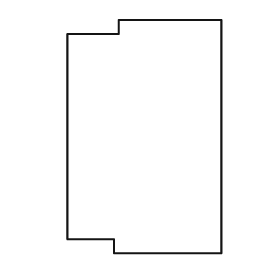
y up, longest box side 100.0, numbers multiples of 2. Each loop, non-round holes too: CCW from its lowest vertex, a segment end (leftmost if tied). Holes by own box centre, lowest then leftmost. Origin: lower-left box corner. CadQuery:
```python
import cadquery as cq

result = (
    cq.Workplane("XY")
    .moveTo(20.0, 0.0)
    .lineTo(66.0, 0.0)
    .lineTo(66.0, 100.0)
    .lineTo(22.0, 100.0)
    .lineTo(22.0, 94.0)
    .lineTo(0.0, 94.0)
    .lineTo(0.0, 6.0)
    .lineTo(20.0, 6.0)
    .close()
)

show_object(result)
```